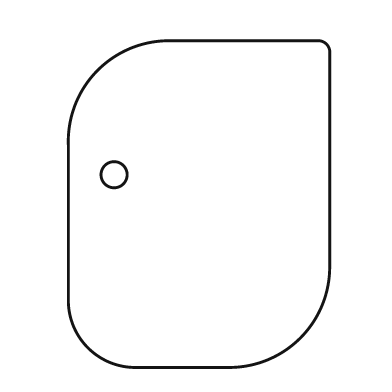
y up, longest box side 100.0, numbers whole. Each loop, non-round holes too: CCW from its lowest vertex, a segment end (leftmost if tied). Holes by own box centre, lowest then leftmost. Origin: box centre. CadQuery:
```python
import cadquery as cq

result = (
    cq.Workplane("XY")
    .moveTo(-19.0, -50.0)
    .lineTo(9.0, -50.0)
    .threePointArc((31.0, -41.0), (40.0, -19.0))
    .lineTo(40.0, 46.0)
    .threePointArc((39.0, 49.0), (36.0, 50.0))
    .lineTo(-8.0, 50.0)
    .threePointArc((-31.0, 41.0), (-40.0, 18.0))
    .lineTo(-40.0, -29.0)
    .threePointArc((-34.0, -44.0), (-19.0, -50.0))
    .close()
    .moveTo(-26.0, 9.0)
    .circle(4.0)
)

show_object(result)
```